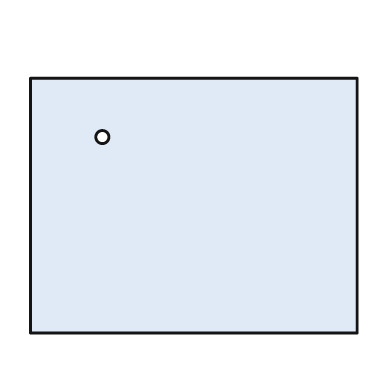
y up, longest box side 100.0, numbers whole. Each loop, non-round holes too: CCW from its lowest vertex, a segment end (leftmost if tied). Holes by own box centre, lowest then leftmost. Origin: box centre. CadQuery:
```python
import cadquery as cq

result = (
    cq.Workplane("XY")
    .moveTo(-50.0, -39.0)
    .lineTo(50.0, -39.0)
    .lineTo(50.0, 39.0)
    .lineTo(-50.0, 39.0)
    .close()
    .moveTo(-28.0, 21.0)
    .circle(2.0)
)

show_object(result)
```